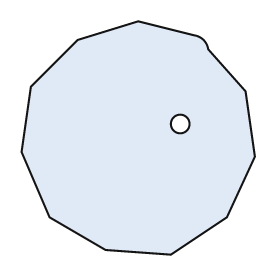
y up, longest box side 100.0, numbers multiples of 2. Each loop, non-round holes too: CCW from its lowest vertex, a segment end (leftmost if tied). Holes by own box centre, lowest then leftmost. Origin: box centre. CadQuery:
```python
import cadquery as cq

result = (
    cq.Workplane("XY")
    .moveTo(14.0, -50.0)
    .lineTo(38.0, -34.0)
    .lineTo(50.0, -8.0)
    .lineTo(46.0, 20.0)
    .lineTo(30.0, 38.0)
    .threePointArc((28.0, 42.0), (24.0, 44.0))
    .lineTo(0.0, 50.0)
    .lineTo(-26.0, 42.0)
    .lineTo(-46.0, 22.0)
    .lineTo(-50.0, -6.0)
    .lineTo(-38.0, -34.0)
    .lineTo(-14.0, -48.0)
    .close()
    .moveTo(18.0, 6.0)
    .circle(4.0)
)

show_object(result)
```